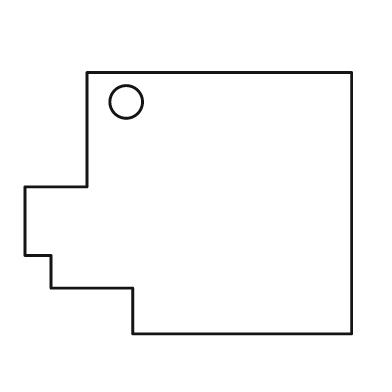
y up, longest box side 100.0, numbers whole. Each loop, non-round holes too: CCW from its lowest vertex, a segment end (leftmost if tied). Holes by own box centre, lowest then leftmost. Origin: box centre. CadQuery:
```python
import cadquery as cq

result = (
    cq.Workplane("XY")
    .moveTo(-17.0, -40.0)
    .lineTo(50.0, -40.0)
    .lineTo(50.0, 40.0)
    .lineTo(-31.0, 40.0)
    .lineTo(-31.0, 5.0)
    .lineTo(-50.0, 5.0)
    .lineTo(-50.0, -16.0)
    .lineTo(-42.0, -16.0)
    .lineTo(-42.0, -26.0)
    .lineTo(-17.0, -26.0)
    .close()
    .moveTo(-19.0, 31.0)
    .circle(5.0)
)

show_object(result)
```